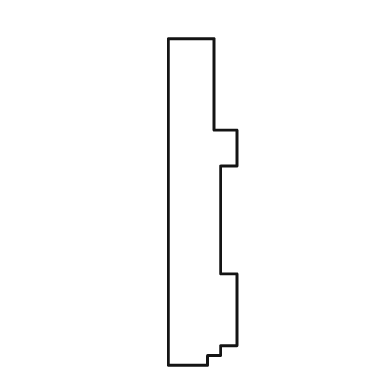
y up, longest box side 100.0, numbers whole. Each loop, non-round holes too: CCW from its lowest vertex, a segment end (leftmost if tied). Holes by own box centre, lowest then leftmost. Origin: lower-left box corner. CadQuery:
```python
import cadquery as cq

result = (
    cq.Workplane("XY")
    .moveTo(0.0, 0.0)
    .lineTo(12.0, 0.0)
    .lineTo(12.0, 3.0)
    .lineTo(16.0, 3.0)
    .lineTo(16.0, 6.0)
    .lineTo(21.0, 6.0)
    .lineTo(21.0, 28.0)
    .lineTo(16.0, 28.0)
    .lineTo(16.0, 61.0)
    .lineTo(21.0, 61.0)
    .lineTo(21.0, 72.0)
    .lineTo(14.0, 72.0)
    .lineTo(14.0, 100.0)
    .lineTo(0.0, 100.0)
    .close()
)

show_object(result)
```